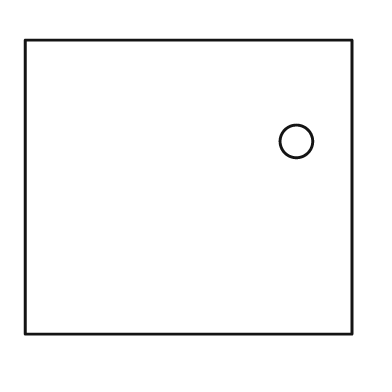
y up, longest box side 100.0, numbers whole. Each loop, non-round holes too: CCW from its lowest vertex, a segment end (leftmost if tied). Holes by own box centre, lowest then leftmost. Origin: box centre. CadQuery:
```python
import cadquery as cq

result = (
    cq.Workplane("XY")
    .moveTo(-50.0, -45.0)
    .lineTo(50.0, -45.0)
    .lineTo(50.0, 45.0)
    .lineTo(-50.0, 45.0)
    .close()
    .moveTo(33.0, 14.0)
    .circle(5.0)
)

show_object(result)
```